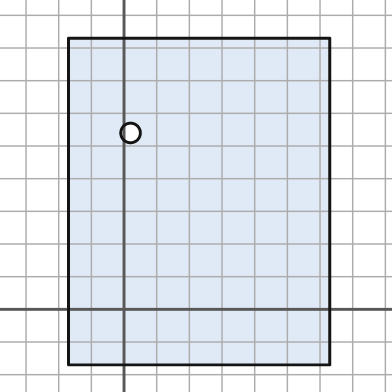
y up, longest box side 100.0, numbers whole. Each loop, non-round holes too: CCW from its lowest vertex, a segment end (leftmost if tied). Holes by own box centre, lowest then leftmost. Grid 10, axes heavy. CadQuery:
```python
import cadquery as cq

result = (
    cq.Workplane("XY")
    .moveTo(-17.0, -17.0)
    .lineTo(63.0, -17.0)
    .lineTo(63.0, 83.0)
    .lineTo(-17.0, 83.0)
    .close()
    .moveTo(2.0, 54.0)
    .circle(3.0)
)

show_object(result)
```